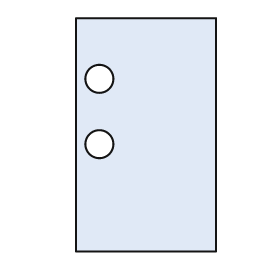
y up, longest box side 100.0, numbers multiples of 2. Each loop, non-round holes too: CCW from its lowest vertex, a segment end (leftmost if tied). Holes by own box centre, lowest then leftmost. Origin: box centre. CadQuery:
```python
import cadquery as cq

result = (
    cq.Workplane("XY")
    .moveTo(-30.0, -50.0)
    .lineTo(30.0, -50.0)
    .lineTo(30.0, 50.0)
    .lineTo(-30.0, 50.0)
    .close()
    .moveTo(-20.0, -4.0)
    .circle(6.0)
    .moveTo(-20.0, 24.0)
    .circle(6.0)
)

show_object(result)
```